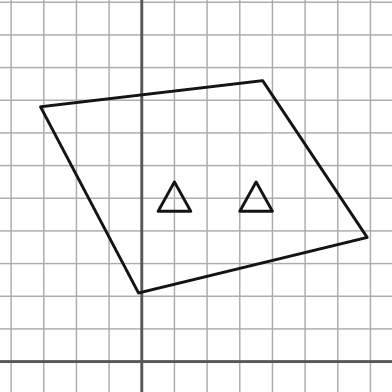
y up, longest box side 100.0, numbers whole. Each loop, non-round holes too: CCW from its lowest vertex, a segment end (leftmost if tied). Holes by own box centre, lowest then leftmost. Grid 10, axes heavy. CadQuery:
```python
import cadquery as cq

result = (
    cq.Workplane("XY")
    .moveTo(-1.0, 21.0)
    .lineTo(69.0, 38.0)
    .lineTo(37.0, 86.0)
    .lineTo(-31.0, 78.0)
    .close()
    .moveTo(5.0, 46.0)
    .lineTo(15.0, 46.0)
    .lineTo(10.0, 55.0)
    .close()
    .moveTo(30.0, 46.0)
    .lineTo(40.0, 46.0)
    .lineTo(35.0, 55.0)
    .close()
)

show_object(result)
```